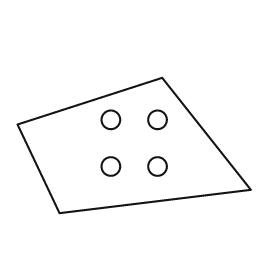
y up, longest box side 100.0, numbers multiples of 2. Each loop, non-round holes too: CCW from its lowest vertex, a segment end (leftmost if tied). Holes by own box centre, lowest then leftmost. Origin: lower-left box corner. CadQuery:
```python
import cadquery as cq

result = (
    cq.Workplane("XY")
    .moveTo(18.0, 0.0)
    .lineTo(100.0, 10.0)
    .lineTo(62.0, 58.0)
    .lineTo(0.0, 38.0)
    .close()
    .moveTo(40.0, 20.0)
    .circle(4.0)
    .moveTo(60.0, 20.0)
    .circle(4.0)
    .moveTo(40.0, 40.0)
    .circle(4.0)
    .moveTo(60.0, 40.0)
    .circle(4.0)
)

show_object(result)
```